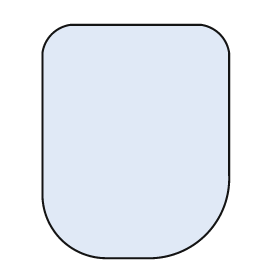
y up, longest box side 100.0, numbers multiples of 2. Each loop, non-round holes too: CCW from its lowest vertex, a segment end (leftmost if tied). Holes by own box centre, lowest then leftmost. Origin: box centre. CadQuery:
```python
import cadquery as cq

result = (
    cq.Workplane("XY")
    .moveTo(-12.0, -50.0)
    .lineTo(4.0, -50.0)
    .threePointArc((30.0, -40.0), (40.0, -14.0))
    .lineTo(40.0, 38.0)
    .threePointArc((36.0, 46.0), (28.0, 50.0))
    .lineTo(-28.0, 50.0)
    .threePointArc((-36.0, 46.0), (-40.0, 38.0))
    .lineTo(-40.0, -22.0)
    .threePointArc((-32.0, -42.0), (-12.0, -50.0))
    .close()
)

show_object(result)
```